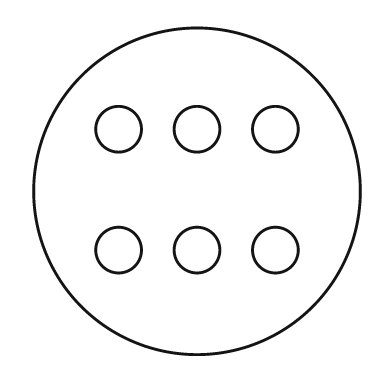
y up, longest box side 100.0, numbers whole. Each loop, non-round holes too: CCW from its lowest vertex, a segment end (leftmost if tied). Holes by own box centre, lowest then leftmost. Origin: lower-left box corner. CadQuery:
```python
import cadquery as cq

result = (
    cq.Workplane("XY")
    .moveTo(50.0, 50.0)
    .circle(50.0)
    .moveTo(26.0, 32.0)
    .circle(7.0)
    .moveTo(50.0, 32.0)
    .circle(7.0)
    .moveTo(74.0, 32.0)
    .circle(7.0)
    .moveTo(26.0, 69.0)
    .circle(7.0)
    .moveTo(50.0, 69.0)
    .circle(7.0)
    .moveTo(74.0, 69.0)
    .circle(7.0)
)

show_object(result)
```